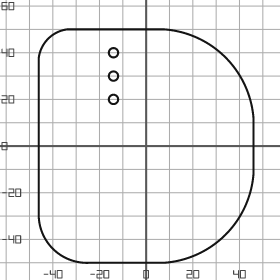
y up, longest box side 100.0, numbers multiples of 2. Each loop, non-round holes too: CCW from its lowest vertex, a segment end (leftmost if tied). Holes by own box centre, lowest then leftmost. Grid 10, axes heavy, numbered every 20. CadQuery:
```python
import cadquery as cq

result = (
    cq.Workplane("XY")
    .moveTo(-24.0, -50.0)
    .lineTo(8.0, -50.0)
    .threePointArc((34.0, -38.0), (46.0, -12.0))
    .lineTo(46.0, 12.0)
    .threePointArc((34.0, 38.0), (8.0, 50.0))
    .lineTo(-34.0, 50.0)
    .threePointArc((-42.0, 46.0), (-46.0, 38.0))
    .lineTo(-46.0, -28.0)
    .threePointArc((-40.0, -44.0), (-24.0, -50.0))
    .close()
    .moveTo(-14.0, 20.0)
    .circle(2.0)
    .moveTo(-14.0, 30.0)
    .circle(2.0)
    .moveTo(-14.0, 40.0)
    .circle(2.0)
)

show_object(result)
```